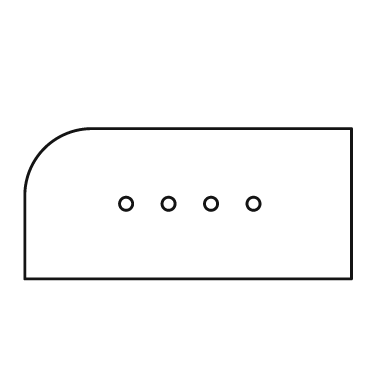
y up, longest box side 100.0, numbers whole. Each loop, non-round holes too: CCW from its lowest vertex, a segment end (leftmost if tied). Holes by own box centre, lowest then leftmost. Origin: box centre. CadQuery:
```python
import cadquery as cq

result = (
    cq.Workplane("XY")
    .moveTo(-50.0, -23.0)
    .lineTo(50.0, -23.0)
    .lineTo(50.0, 23.0)
    .lineTo(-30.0, 23.0)
    .threePointArc((-44.0, 17.0), (-50.0, 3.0))
    .close()
    .moveTo(-19.0, 0.0)
    .circle(2.0)
    .moveTo(-6.0, 0.0)
    .circle(2.0)
    .moveTo(7.0, 0.0)
    .circle(2.0)
    .moveTo(20.0, 0.0)
    .circle(2.0)
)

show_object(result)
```